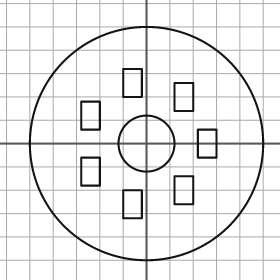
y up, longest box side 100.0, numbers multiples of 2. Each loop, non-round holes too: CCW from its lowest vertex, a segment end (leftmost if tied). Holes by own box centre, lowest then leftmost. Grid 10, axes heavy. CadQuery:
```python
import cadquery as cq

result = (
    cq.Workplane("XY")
    .moveTo(0.0, 0.0)
    .circle(50.0)
    .moveTo(-10.0, -32.0)
    .lineTo(-2.0, -32.0)
    .lineTo(-2.0, -20.0)
    .lineTo(-10.0, -20.0)
    .close()
    .moveTo(12.0, -26.0)
    .lineTo(20.0, -26.0)
    .lineTo(20.0, -14.0)
    .lineTo(12.0, -14.0)
    .close()
    .moveTo(-28.0, -18.0)
    .lineTo(-20.0, -18.0)
    .lineTo(-20.0, -6.0)
    .lineTo(-28.0, -6.0)
    .close()
    .moveTo(0.0, 0.0)
    .circle(12.0)
    .moveTo(22.0, -6.0)
    .lineTo(30.0, -6.0)
    .lineTo(30.0, 6.0)
    .lineTo(22.0, 6.0)
    .close()
    .moveTo(-28.0, 6.0)
    .lineTo(-20.0, 6.0)
    .lineTo(-20.0, 18.0)
    .lineTo(-28.0, 18.0)
    .close()
    .moveTo(12.0, 14.0)
    .lineTo(20.0, 14.0)
    .lineTo(20.0, 26.0)
    .lineTo(12.0, 26.0)
    .close()
    .moveTo(-10.0, 20.0)
    .lineTo(-2.0, 20.0)
    .lineTo(-2.0, 32.0)
    .lineTo(-10.0, 32.0)
    .close()
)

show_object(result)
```